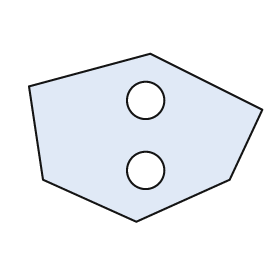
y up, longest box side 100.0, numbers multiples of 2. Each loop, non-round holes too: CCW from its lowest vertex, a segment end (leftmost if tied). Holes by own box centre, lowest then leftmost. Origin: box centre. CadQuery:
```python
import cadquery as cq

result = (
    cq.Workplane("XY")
    .moveTo(-4.0, -36.0)
    .lineTo(36.0, -18.0)
    .lineTo(50.0, 12.0)
    .lineTo(2.0, 36.0)
    .lineTo(-50.0, 22.0)
    .lineTo(-44.0, -18.0)
    .close()
    .moveTo(0.0, -14.0)
    .circle(8.0)
    .moveTo(0.0, 16.0)
    .circle(8.0)
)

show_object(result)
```